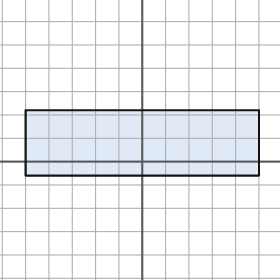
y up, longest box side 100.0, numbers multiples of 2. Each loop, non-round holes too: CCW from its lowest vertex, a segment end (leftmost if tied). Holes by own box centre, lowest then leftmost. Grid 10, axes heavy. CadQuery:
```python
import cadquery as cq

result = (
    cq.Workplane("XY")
    .moveTo(-50.0, -6.0)
    .lineTo(50.0, -6.0)
    .lineTo(50.0, 22.0)
    .lineTo(-50.0, 22.0)
    .close()
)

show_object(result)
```